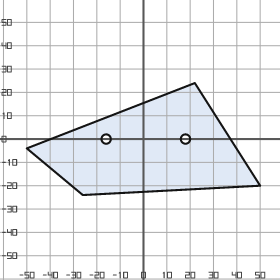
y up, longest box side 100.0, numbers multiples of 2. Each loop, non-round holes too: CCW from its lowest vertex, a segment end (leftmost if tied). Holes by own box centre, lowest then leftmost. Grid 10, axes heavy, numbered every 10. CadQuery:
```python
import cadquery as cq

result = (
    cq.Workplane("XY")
    .moveTo(-26.0, -24.0)
    .lineTo(50.0, -20.0)
    .lineTo(22.0, 24.0)
    .lineTo(-50.0, -4.0)
    .close()
    .moveTo(-16.0, 0.0)
    .circle(2.0)
    .moveTo(18.0, 0.0)
    .circle(2.0)
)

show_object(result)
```